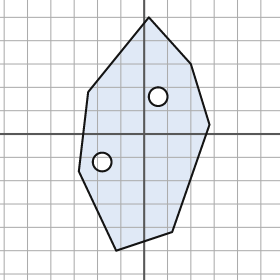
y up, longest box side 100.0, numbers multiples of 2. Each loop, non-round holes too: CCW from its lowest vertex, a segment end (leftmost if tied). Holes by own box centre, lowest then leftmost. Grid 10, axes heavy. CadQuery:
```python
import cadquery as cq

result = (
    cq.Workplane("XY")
    .moveTo(-12.0, -50.0)
    .lineTo(12.0, -42.0)
    .lineTo(28.0, 4.0)
    .lineTo(20.0, 30.0)
    .lineTo(2.0, 50.0)
    .lineTo(-24.0, 18.0)
    .lineTo(-28.0, -16.0)
    .close()
    .moveTo(-18.0, -12.0)
    .circle(4.0)
    .moveTo(6.0, 16.0)
    .circle(4.0)
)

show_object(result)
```